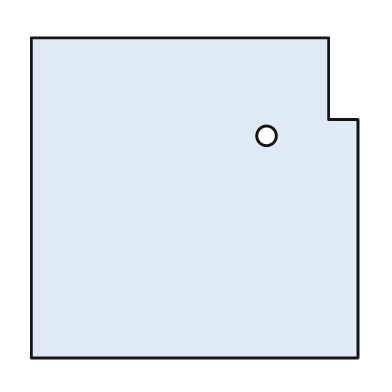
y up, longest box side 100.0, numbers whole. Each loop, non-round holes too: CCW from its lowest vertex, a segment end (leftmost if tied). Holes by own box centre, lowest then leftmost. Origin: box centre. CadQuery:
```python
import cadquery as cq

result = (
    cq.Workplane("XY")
    .moveTo(-50.0, -49.0)
    .lineTo(50.0, -49.0)
    .lineTo(50.0, 24.0)
    .lineTo(41.0, 24.0)
    .lineTo(41.0, 49.0)
    .lineTo(-50.0, 49.0)
    .close()
    .moveTo(22.0, 19.0)
    .circle(3.0)
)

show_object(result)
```